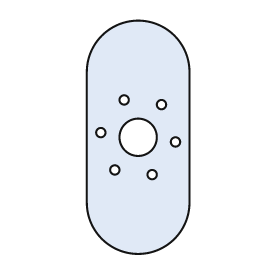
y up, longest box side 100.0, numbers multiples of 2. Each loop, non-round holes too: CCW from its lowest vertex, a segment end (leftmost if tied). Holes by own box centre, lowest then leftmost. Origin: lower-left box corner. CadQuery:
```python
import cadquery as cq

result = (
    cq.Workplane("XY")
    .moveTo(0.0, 22.0)
    .threePointArc((22.0, 0.0), (44.0, 22.0))
    .lineTo(44.0, 78.0)
    .threePointArc((22.0, 100.0), (0.0, 78.0))
    .close()
    .moveTo(28.0, 34.0)
    .circle(2.0)
    .moveTo(12.0, 36.0)
    .circle(2.0)
    .moveTo(38.0, 48.0)
    .circle(2.0)
    .moveTo(22.0, 50.0)
    .circle(8.0)
    .moveTo(6.0, 52.0)
    .circle(2.0)
    .moveTo(32.0, 64.0)
    .circle(2.0)
    .moveTo(16.0, 66.0)
    .circle(2.0)
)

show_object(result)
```